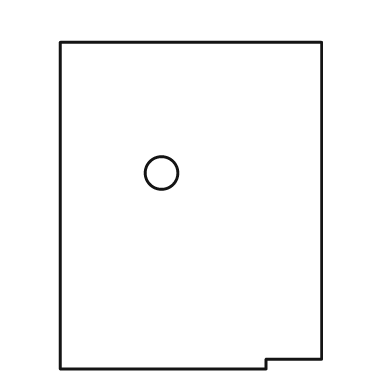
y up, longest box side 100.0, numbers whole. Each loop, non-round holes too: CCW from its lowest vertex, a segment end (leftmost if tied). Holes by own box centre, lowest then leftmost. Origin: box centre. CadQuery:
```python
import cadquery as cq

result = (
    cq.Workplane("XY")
    .moveTo(-40.0, -50.0)
    .lineTo(23.0, -50.0)
    .lineTo(23.0, -47.0)
    .lineTo(40.0, -47.0)
    .lineTo(40.0, 50.0)
    .lineTo(-40.0, 50.0)
    .close()
    .moveTo(-9.0, 10.0)
    .circle(5.0)
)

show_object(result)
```